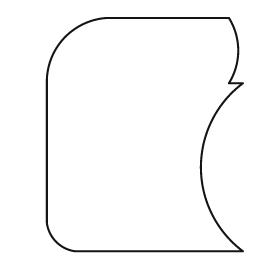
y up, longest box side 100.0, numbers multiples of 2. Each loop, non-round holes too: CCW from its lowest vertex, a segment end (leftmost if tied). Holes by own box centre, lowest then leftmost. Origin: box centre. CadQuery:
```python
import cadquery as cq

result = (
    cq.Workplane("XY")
    .moveTo(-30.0, -50.0)
    .lineTo(42.0, -50.0)
    .threePointArc((24.0, -14.0), (42.0, 22.0))
    .lineTo(36.0, 22.0)
    .threePointArc((40.0, 36.0), (36.0, 50.0))
    .lineTo(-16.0, 50.0)
    .threePointArc((-34.0, 42.0), (-42.0, 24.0))
    .lineTo(-42.0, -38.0)
    .threePointArc((-38.0, -46.0), (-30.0, -50.0))
    .close()
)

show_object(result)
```